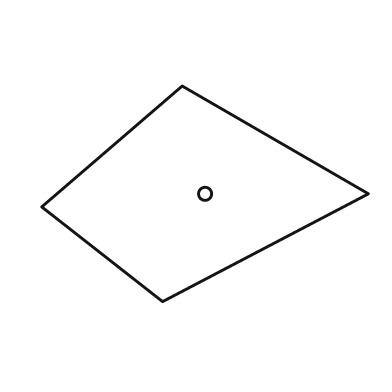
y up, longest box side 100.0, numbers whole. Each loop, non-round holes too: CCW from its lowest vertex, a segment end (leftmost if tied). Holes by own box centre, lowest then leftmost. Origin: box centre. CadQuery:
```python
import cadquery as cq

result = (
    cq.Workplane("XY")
    .moveTo(-13.0, -33.0)
    .lineTo(50.0, 0.0)
    .lineTo(-7.0, 33.0)
    .lineTo(-50.0, -4.0)
    .close()
    .moveTo(0.0, 0.0)
    .circle(2.0)
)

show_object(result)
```